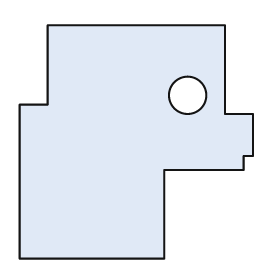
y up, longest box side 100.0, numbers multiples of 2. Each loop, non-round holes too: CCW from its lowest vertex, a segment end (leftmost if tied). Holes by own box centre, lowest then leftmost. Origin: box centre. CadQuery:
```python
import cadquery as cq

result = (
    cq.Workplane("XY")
    .moveTo(-50.0, -50.0)
    .lineTo(12.0, -50.0)
    .lineTo(12.0, -12.0)
    .lineTo(46.0, -12.0)
    .lineTo(46.0, -6.0)
    .lineTo(50.0, -6.0)
    .lineTo(50.0, 12.0)
    .lineTo(38.0, 12.0)
    .lineTo(38.0, 50.0)
    .lineTo(-38.0, 50.0)
    .lineTo(-38.0, 16.0)
    .lineTo(-50.0, 16.0)
    .close()
    .moveTo(22.0, 20.0)
    .circle(8.0)
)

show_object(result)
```